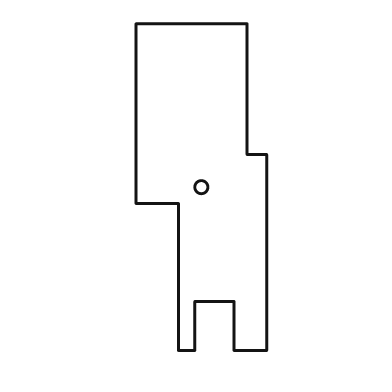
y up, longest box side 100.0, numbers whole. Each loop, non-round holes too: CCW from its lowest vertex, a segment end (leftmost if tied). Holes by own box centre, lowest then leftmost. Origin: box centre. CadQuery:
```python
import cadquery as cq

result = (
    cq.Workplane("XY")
    .moveTo(-7.0, -50.0)
    .lineTo(-2.0, -50.0)
    .lineTo(-2.0, -35.0)
    .lineTo(10.0, -35.0)
    .lineTo(10.0, -50.0)
    .lineTo(20.0, -50.0)
    .lineTo(20.0, 10.0)
    .lineTo(14.0, 10.0)
    .lineTo(14.0, 50.0)
    .lineTo(-20.0, 50.0)
    .lineTo(-20.0, -5.0)
    .lineTo(-7.0, -5.0)
    .close()
    .moveTo(0.0, 0.0)
    .circle(2.0)
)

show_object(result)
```